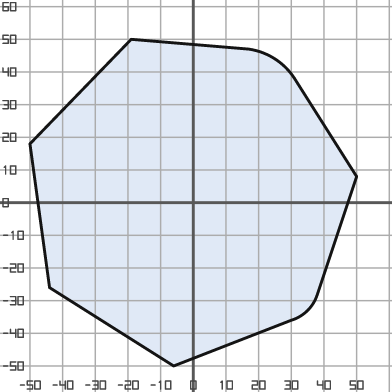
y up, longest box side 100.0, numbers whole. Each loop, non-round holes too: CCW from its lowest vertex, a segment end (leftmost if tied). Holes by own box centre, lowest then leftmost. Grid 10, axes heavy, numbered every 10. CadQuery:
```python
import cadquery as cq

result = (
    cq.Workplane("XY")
    .moveTo(-6.0, -50.0)
    .lineTo(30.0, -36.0)
    .threePointArc((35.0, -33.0), (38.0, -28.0))
    .lineTo(50.0, 8.0)
    .lineTo(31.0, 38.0)
    .threePointArc((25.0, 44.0), (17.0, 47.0))
    .lineTo(-19.0, 50.0)
    .lineTo(-50.0, 18.0)
    .lineTo(-44.0, -26.0)
    .close()
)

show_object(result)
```